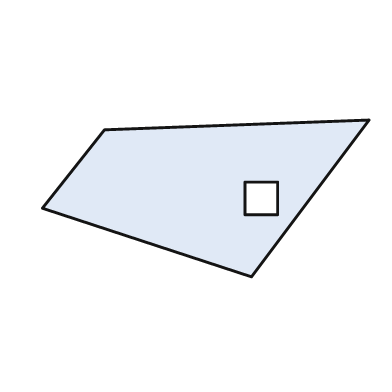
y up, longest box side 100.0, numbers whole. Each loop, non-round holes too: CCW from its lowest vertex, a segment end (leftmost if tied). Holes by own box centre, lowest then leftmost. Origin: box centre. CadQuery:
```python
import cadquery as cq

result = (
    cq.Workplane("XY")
    .moveTo(14.0, -24.0)
    .lineTo(50.0, 24.0)
    .lineTo(-31.0, 21.0)
    .lineTo(-50.0, -3.0)
    .close()
    .moveTo(12.0, -5.0)
    .lineTo(22.0, -5.0)
    .lineTo(22.0, 5.0)
    .lineTo(12.0, 5.0)
    .close()
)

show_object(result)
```